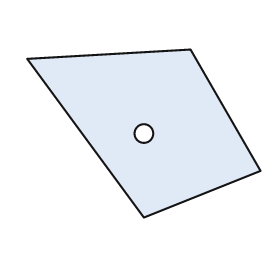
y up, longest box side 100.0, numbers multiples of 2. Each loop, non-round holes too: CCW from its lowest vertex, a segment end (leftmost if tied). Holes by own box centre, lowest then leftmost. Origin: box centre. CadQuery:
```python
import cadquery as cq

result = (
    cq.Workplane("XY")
    .moveTo(0.0, -36.0)
    .lineTo(50.0, -16.0)
    .lineTo(20.0, 36.0)
    .lineTo(-50.0, 32.0)
    .close()
    .moveTo(0.0, 0.0)
    .circle(4.0)
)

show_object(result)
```